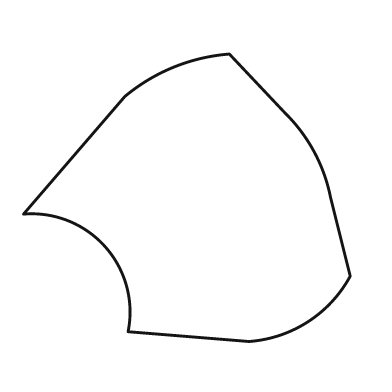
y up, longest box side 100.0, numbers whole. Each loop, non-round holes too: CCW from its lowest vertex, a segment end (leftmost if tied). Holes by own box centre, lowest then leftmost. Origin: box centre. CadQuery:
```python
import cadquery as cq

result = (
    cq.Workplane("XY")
    .moveTo(19.0, -44.0)
    .threePointArc((37.0, -38.0), (50.0, -24.0))
    .lineTo(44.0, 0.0)
    .threePointArc((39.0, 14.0), (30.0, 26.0))
    .lineTo(13.0, 44.0)
    .threePointArc((-4.0, 40.0), (-19.0, 31.0))
    .lineTo(-50.0, -5.0)
    .threePointArc((-25.0, -15.0), (-18.0, -41.0))
    .close()
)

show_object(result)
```